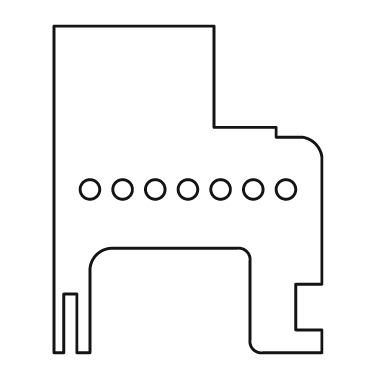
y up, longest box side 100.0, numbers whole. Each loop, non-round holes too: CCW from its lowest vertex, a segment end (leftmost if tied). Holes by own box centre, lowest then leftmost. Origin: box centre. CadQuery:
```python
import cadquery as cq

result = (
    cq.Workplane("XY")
    .moveTo(-41.0, -50.0)
    .lineTo(-38.0, -50.0)
    .lineTo(-38.0, -32.0)
    .lineTo(-34.0, -32.0)
    .lineTo(-34.0, -50.0)
    .lineTo(-30.0, -50.0)
    .lineTo(-30.0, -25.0)
    .threePointArc((-28.0, -20.0), (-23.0, -18.0))
    .lineTo(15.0, -18.0)
    .threePointArc((18.0, -19.0), (19.0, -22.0))
    .lineTo(19.0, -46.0)
    .threePointArc((20.0, -49.0), (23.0, -50.0))
    .lineTo(41.0, -50.0)
    .lineTo(41.0, -43.0)
    .lineTo(33.0, -43.0)
    .lineTo(33.0, -29.0)
    .lineTo(41.0, -29.0)
    .lineTo(41.0, 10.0)
    .threePointArc((39.0, 14.0), (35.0, 16.0))
    .lineTo(27.0, 16.0)
    .lineTo(27.0, 19.0)
    .lineTo(8.0, 19.0)
    .lineTo(8.0, 50.0)
    .lineTo(-41.0, 50.0)
    .close()
    .moveTo(-30.0, 0.0)
    .circle(3.0)
    .moveTo(-20.0, 0.0)
    .circle(3.0)
    .moveTo(-10.0, 0.0)
    .circle(3.0)
    .moveTo(0.0, 0.0)
    .circle(3.0)
    .moveTo(10.0, 0.0)
    .circle(3.0)
    .moveTo(20.0, 0.0)
    .circle(3.0)
    .moveTo(30.0, 0.0)
    .circle(3.0)
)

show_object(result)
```